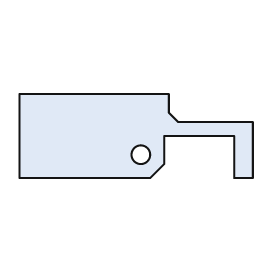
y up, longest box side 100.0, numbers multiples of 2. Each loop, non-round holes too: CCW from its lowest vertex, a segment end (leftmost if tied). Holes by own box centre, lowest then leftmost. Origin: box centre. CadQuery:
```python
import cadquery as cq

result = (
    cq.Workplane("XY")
    .moveTo(-50.0, -18.0)
    .lineTo(6.0, -18.0)
    .lineTo(12.0, -12.0)
    .lineTo(12.0, 0.0)
    .lineTo(42.0, 0.0)
    .lineTo(42.0, -18.0)
    .lineTo(50.0, -18.0)
    .lineTo(50.0, 6.0)
    .lineTo(18.0, 6.0)
    .lineTo(14.0, 10.0)
    .lineTo(14.0, 18.0)
    .lineTo(-50.0, 18.0)
    .close()
    .moveTo(2.0, -8.0)
    .circle(4.0)
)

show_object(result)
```